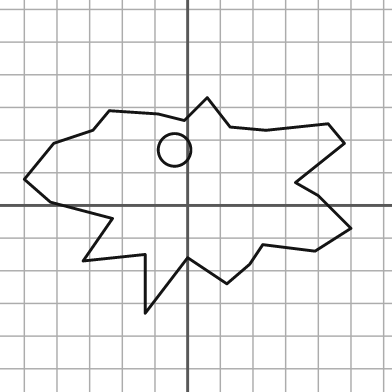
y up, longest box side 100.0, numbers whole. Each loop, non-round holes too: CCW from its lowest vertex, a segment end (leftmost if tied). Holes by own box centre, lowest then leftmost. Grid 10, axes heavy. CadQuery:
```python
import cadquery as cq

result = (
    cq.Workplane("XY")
    .moveTo(-13.0, -33.0)
    .lineTo(0.0, -16.0)
    .lineTo(12.0, -24.0)
    .lineTo(19.0, -18.0)
    .lineTo(23.0, -12.0)
    .lineTo(39.0, -14.0)
    .lineTo(50.0, -7.0)
    .lineTo(40.0, 3.0)
    .lineTo(33.0, 7.0)
    .lineTo(48.0, 19.0)
    .lineTo(43.0, 25.0)
    .lineTo(24.0, 23.0)
    .lineTo(13.0, 24.0)
    .lineTo(6.0, 33.0)
    .lineTo(-1.0, 26.0)
    .lineTo(-9.0, 28.0)
    .lineTo(-24.0, 29.0)
    .lineTo(-29.0, 23.0)
    .lineTo(-41.0, 19.0)
    .lineTo(-50.0, 8.0)
    .lineTo(-42.0, 1.0)
    .lineTo(-23.0, -4.0)
    .lineTo(-32.0, -17.0)
    .lineTo(-13.0, -15.0)
    .close()
    .moveTo(-4.0, 17.0)
    .circle(5.0)
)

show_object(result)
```